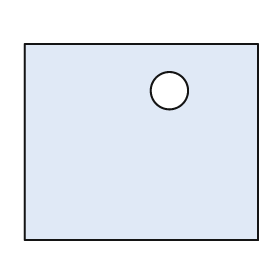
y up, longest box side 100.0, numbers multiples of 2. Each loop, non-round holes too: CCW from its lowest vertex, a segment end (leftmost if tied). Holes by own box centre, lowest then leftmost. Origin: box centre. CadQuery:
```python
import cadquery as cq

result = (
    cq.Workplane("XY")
    .moveTo(-50.0, -42.0)
    .lineTo(50.0, -42.0)
    .lineTo(50.0, 42.0)
    .lineTo(-50.0, 42.0)
    .close()
    .moveTo(12.0, 22.0)
    .circle(8.0)
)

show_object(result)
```